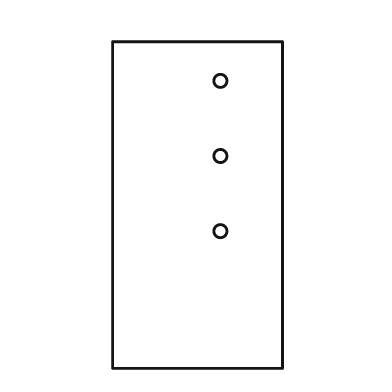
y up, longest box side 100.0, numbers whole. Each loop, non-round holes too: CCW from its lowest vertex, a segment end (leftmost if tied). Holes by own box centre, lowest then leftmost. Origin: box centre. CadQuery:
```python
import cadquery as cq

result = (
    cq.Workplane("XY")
    .moveTo(-26.0, -50.0)
    .lineTo(26.0, -50.0)
    .lineTo(26.0, 50.0)
    .lineTo(-26.0, 50.0)
    .close()
    .moveTo(7.0, -8.0)
    .circle(2.0)
    .moveTo(7.0, 15.0)
    .circle(2.0)
    .moveTo(7.0, 38.0)
    .circle(2.0)
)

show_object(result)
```